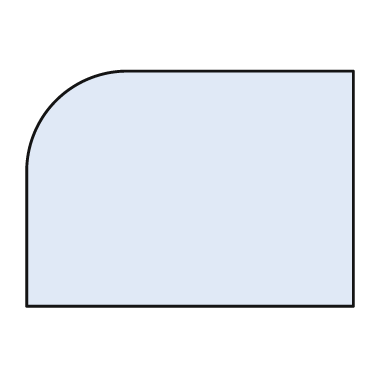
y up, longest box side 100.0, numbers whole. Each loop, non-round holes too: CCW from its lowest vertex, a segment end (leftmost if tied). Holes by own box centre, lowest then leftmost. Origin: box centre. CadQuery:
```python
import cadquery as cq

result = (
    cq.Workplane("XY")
    .moveTo(-50.0, -36.0)
    .lineTo(50.0, -36.0)
    .lineTo(50.0, 36.0)
    .lineTo(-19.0, 36.0)
    .threePointArc((-41.0, 27.0), (-50.0, 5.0))
    .close()
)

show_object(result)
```